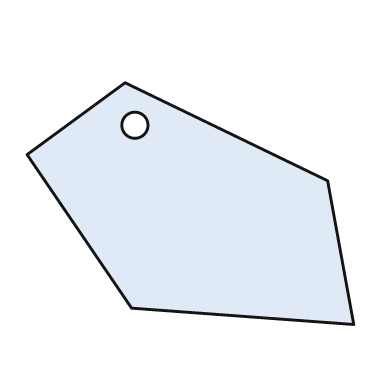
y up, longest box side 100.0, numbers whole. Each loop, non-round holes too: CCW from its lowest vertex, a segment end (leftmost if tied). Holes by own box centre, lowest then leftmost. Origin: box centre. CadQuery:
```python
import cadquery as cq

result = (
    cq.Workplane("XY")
    .moveTo(50.0, -37.0)
    .lineTo(42.0, 7.0)
    .lineTo(-20.0, 37.0)
    .lineTo(-50.0, 15.0)
    .lineTo(-18.0, -32.0)
    .close()
    .moveTo(-17.0, 24.0)
    .circle(4.0)
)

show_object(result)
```